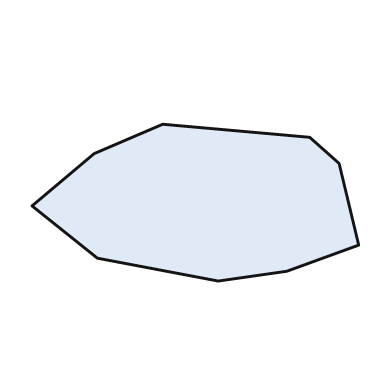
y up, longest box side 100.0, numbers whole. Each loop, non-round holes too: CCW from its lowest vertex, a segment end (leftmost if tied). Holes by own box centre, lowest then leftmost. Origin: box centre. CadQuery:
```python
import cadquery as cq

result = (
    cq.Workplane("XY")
    .moveTo(7.0, -24.0)
    .lineTo(28.0, -21.0)
    .lineTo(50.0, -13.0)
    .lineTo(44.0, 12.0)
    .lineTo(35.0, 20.0)
    .lineTo(-10.0, 24.0)
    .lineTo(-31.0, 15.0)
    .lineTo(-50.0, -1.0)
    .lineTo(-30.0, -17.0)
    .close()
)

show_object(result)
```